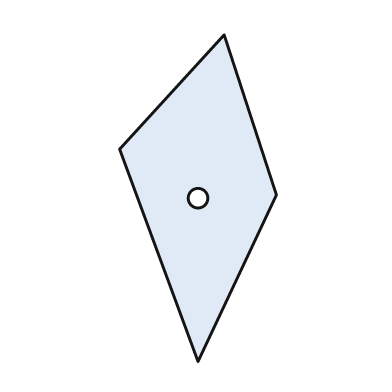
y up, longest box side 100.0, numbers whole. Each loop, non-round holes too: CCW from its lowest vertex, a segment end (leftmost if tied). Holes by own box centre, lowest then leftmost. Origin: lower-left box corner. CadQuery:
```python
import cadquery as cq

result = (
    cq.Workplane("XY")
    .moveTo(24.0, 0.0)
    .lineTo(48.0, 51.0)
    .lineTo(32.0, 100.0)
    .lineTo(0.0, 65.0)
    .close()
    .moveTo(24.0, 50.0)
    .circle(3.0)
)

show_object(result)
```